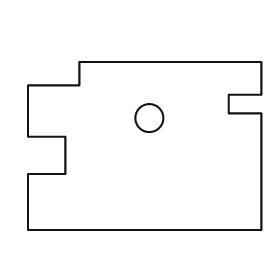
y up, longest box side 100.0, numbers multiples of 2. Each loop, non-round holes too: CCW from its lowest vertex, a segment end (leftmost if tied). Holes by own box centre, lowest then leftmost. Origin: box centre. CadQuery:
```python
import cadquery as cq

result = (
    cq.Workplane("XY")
    .moveTo(-50.0, -36.0)
    .lineTo(50.0, -36.0)
    .lineTo(50.0, 14.0)
    .lineTo(36.0, 14.0)
    .lineTo(36.0, 22.0)
    .lineTo(50.0, 22.0)
    .lineTo(50.0, 36.0)
    .lineTo(-28.0, 36.0)
    .lineTo(-28.0, 26.0)
    .lineTo(-50.0, 26.0)
    .lineTo(-50.0, 4.0)
    .lineTo(-34.0, 4.0)
    .lineTo(-34.0, -12.0)
    .lineTo(-50.0, -12.0)
    .close()
    .moveTo(2.0, 12.0)
    .circle(6.0)
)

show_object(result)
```